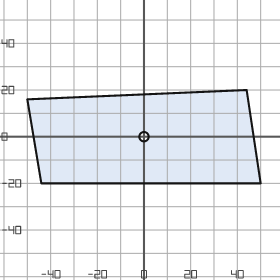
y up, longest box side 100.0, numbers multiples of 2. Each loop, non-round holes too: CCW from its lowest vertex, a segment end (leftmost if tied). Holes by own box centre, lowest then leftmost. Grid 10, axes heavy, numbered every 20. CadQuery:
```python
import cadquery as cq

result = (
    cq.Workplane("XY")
    .moveTo(-44.0, -20.0)
    .lineTo(50.0, -20.0)
    .lineTo(44.0, 20.0)
    .lineTo(-50.0, 16.0)
    .close()
    .moveTo(0.0, 0.0)
    .circle(2.0)
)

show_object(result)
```